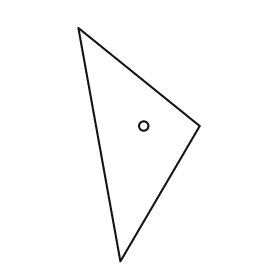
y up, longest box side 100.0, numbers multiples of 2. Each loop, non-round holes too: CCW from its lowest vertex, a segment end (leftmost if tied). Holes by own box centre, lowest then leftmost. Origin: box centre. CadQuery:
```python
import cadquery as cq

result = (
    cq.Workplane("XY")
    .moveTo(-8.0, -50.0)
    .lineTo(26.0, 8.0)
    .lineTo(-26.0, 50.0)
    .close()
    .moveTo(2.0, 8.0)
    .circle(2.0)
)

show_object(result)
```